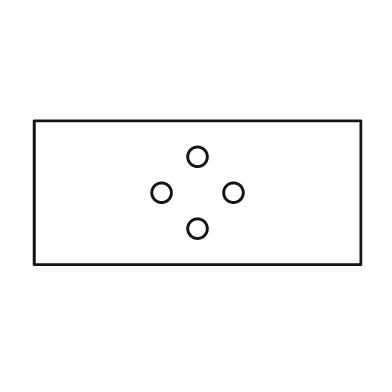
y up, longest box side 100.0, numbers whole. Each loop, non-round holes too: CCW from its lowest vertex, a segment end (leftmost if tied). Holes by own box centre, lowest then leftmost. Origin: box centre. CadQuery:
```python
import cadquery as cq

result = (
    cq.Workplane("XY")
    .moveTo(-50.0, -22.0)
    .lineTo(50.0, -22.0)
    .lineTo(50.0, 22.0)
    .lineTo(-50.0, 22.0)
    .close()
    .moveTo(0.0, -11.0)
    .circle(3.0)
    .moveTo(-11.0, 0.0)
    .circle(3.0)
    .moveTo(11.0, 0.0)
    .circle(3.0)
    .moveTo(0.0, 11.0)
    .circle(3.0)
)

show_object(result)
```